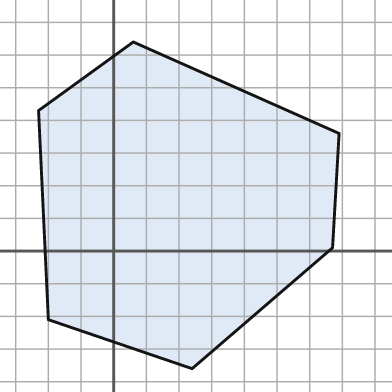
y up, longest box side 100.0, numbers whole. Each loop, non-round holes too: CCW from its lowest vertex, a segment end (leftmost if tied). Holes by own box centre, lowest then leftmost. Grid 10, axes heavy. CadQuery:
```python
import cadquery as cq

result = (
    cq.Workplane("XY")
    .moveTo(24.0, -36.0)
    .lineTo(67.0, 1.0)
    .lineTo(69.0, 36.0)
    .lineTo(6.0, 64.0)
    .lineTo(-23.0, 43.0)
    .lineTo(-20.0, -21.0)
    .close()
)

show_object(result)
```